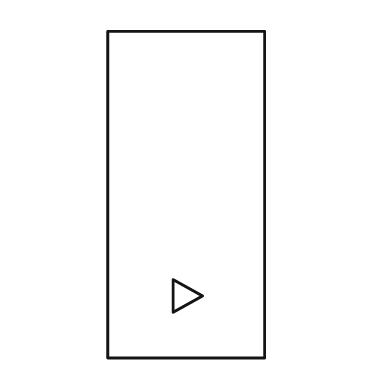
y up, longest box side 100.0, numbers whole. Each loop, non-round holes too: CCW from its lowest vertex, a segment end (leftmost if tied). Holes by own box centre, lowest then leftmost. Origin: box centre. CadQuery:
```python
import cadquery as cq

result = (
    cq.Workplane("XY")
    .moveTo(-24.0, -50.0)
    .lineTo(24.0, -50.0)
    .lineTo(24.0, 50.0)
    .lineTo(-24.0, 50.0)
    .close()
    .moveTo(-4.0, -36.0)
    .lineTo(5.0, -31.0)
    .lineTo(-4.0, -26.0)
    .close()
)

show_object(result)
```